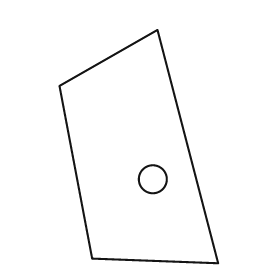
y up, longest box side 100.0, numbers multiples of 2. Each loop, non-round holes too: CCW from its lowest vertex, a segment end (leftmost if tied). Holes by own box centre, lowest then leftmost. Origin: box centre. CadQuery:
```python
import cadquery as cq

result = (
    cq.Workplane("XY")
    .moveTo(34.0, -50.0)
    .lineTo(8.0, 50.0)
    .lineTo(-34.0, 26.0)
    .lineTo(-20.0, -48.0)
    .close()
    .moveTo(6.0, -14.0)
    .circle(6.0)
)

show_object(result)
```